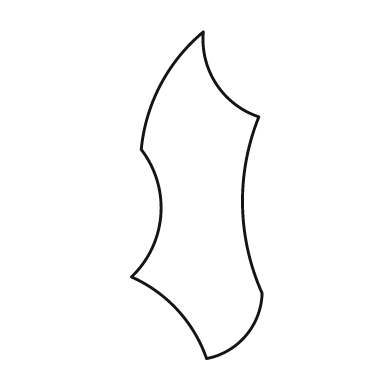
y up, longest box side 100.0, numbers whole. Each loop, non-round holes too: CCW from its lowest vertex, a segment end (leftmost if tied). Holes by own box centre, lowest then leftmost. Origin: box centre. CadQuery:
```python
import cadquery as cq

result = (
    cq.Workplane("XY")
    .moveTo(3.0, -50.0)
    .threePointArc((15.0, -43.0), (20.0, -30.0))
    .threePointArc((14.0, -3.0), (19.0, 24.0))
    .threePointArc((6.0, 34.0), (2.0, 50.0))
    .threePointArc((-11.0, 34.0), (-17.0, 14.0))
    .threePointArc((-11.0, -6.0), (-20.0, -25.0))
    .threePointArc((-6.0, -35.0), (3.0, -50.0))
    .close()
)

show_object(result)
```